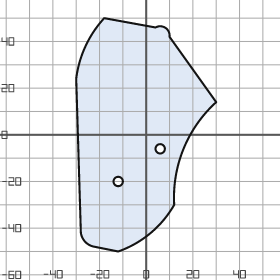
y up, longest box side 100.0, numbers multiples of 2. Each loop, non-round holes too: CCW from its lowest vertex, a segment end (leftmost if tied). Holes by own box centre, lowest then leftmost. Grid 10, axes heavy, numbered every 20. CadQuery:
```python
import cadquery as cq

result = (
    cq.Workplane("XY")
    .moveTo(-12.0, -50.0)
    .threePointArc((2.0, -42.0), (12.0, -30.0))
    .threePointArc((16.0, -6.0), (30.0, 14.0))
    .lineTo(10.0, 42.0)
    .threePointArc((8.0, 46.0), (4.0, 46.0))
    .lineTo(-18.0, 50.0)
    .threePointArc((-26.0, 38.0), (-30.0, 24.0))
    .lineTo(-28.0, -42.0)
    .threePointArc((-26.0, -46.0), (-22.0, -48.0))
    .close()
    .moveTo(-12.0, -20.0)
    .circle(2.0)
    .moveTo(6.0, -6.0)
    .circle(2.0)
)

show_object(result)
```